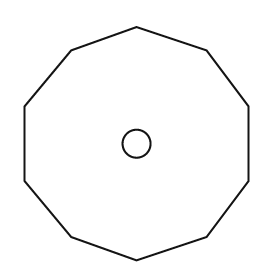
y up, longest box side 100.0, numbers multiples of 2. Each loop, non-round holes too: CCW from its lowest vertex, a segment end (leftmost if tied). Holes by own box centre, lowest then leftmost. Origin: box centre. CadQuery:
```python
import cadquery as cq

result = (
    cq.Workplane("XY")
    .moveTo(0.0, -50.0)
    .lineTo(30.0, -40.0)
    .lineTo(48.0, -16.0)
    .lineTo(48.0, 16.0)
    .lineTo(30.0, 40.0)
    .lineTo(0.0, 50.0)
    .lineTo(-28.0, 40.0)
    .lineTo(-48.0, 16.0)
    .lineTo(-48.0, -16.0)
    .lineTo(-28.0, -40.0)
    .close()
    .moveTo(0.0, 0.0)
    .circle(6.0)
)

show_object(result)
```